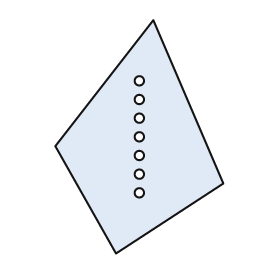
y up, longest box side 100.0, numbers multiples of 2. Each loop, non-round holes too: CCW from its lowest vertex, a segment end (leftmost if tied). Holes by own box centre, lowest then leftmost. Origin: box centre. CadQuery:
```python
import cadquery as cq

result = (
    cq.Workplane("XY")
    .moveTo(-10.0, -50.0)
    .lineTo(36.0, -20.0)
    .lineTo(6.0, 50.0)
    .lineTo(-36.0, -4.0)
    .close()
    .moveTo(0.0, -24.0)
    .circle(2.0)
    .moveTo(0.0, -16.0)
    .circle(2.0)
    .moveTo(0.0, -8.0)
    .circle(2.0)
    .moveTo(0.0, 0.0)
    .circle(2.0)
    .moveTo(0.0, 8.0)
    .circle(2.0)
    .moveTo(0.0, 16.0)
    .circle(2.0)
    .moveTo(0.0, 24.0)
    .circle(2.0)
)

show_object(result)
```